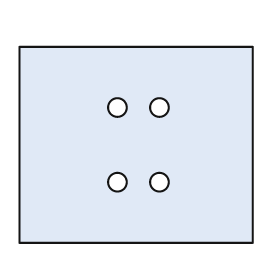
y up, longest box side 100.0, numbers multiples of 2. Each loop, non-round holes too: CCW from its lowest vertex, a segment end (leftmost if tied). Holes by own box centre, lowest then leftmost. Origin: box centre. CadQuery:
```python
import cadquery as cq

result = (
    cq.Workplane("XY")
    .moveTo(-50.0, -42.0)
    .lineTo(50.0, -42.0)
    .lineTo(50.0, 42.0)
    .lineTo(-50.0, 42.0)
    .close()
    .moveTo(-8.0, -16.0)
    .circle(4.0)
    .moveTo(10.0, -16.0)
    .circle(4.0)
    .moveTo(-8.0, 16.0)
    .circle(4.0)
    .moveTo(10.0, 16.0)
    .circle(4.0)
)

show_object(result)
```